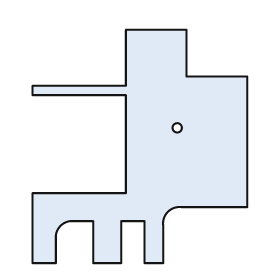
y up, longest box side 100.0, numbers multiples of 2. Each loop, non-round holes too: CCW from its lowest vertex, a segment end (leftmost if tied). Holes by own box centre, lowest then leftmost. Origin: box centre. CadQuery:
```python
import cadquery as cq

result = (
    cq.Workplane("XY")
    .moveTo(-46.0, -50.0)
    .lineTo(-36.0, -50.0)
    .lineTo(-36.0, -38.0)
    .threePointArc((-34.0, -34.0), (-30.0, -32.0))
    .lineTo(-20.0, -32.0)
    .lineTo(-20.0, -50.0)
    .lineTo(-8.0, -50.0)
    .lineTo(-8.0, -32.0)
    .lineTo(2.0, -32.0)
    .lineTo(2.0, -50.0)
    .lineTo(10.0, -50.0)
    .lineTo(10.0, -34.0)
    .threePointArc((12.0, -28.0), (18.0, -26.0))
    .lineTo(46.0, -26.0)
    .lineTo(46.0, 30.0)
    .lineTo(20.0, 30.0)
    .lineTo(20.0, 50.0)
    .lineTo(-6.0, 50.0)
    .lineTo(-6.0, 26.0)
    .lineTo(-46.0, 26.0)
    .lineTo(-46.0, 22.0)
    .lineTo(-6.0, 22.0)
    .lineTo(-6.0, -20.0)
    .lineTo(-46.0, -20.0)
    .close()
    .moveTo(16.0, 8.0)
    .circle(2.0)
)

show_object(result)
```